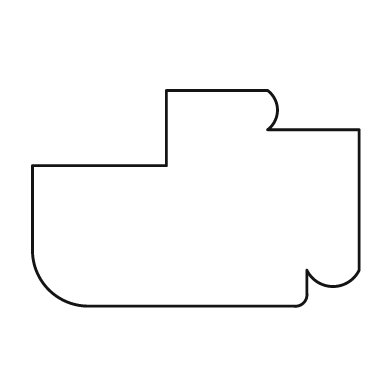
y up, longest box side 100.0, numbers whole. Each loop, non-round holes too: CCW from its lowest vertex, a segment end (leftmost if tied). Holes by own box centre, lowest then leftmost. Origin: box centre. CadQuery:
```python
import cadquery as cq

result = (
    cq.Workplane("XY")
    .moveTo(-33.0, -33.0)
    .lineTo(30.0, -33.0)
    .threePointArc((33.0, -32.0), (34.0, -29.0))
    .lineTo(34.0, -22.0)
    .threePointArc((42.0, -27.0), (50.0, -22.0))
    .lineTo(50.0, 21.0)
    .lineTo(22.0, 21.0)
    .threePointArc((25.0, 27.0), (22.0, 33.0))
    .lineTo(-9.0, 33.0)
    .lineTo(-9.0, 10.0)
    .lineTo(-50.0, 10.0)
    .lineTo(-50.0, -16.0)
    .threePointArc((-45.0, -28.0), (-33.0, -33.0))
    .close()
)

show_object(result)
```